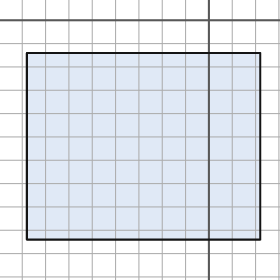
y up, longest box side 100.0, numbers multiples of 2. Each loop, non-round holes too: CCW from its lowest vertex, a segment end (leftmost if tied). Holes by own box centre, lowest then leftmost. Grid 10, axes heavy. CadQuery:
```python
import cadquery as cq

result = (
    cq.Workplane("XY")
    .moveTo(-78.0, -94.0)
    .lineTo(22.0, -94.0)
    .lineTo(22.0, -14.0)
    .lineTo(-78.0, -14.0)
    .close()
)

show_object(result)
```